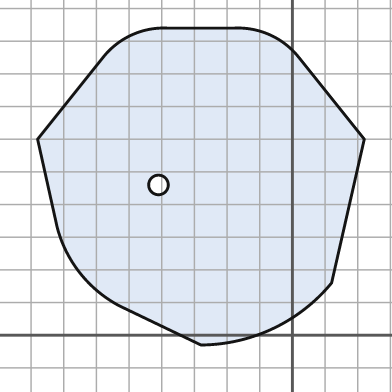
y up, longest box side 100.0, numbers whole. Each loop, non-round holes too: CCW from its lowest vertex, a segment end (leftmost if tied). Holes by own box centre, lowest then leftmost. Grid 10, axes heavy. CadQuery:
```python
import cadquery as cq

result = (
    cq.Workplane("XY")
    .moveTo(-28.0, -3.0)
    .threePointArc((-6.0, 2.0), (12.0, 16.0))
    .lineTo(22.0, 60.0)
    .lineTo(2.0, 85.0)
    .threePointArc((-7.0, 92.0), (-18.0, 94.0))
    .lineTo(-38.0, 94.0)
    .threePointArc((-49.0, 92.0), (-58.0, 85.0))
    .lineTo(-78.0, 60.0)
    .lineTo(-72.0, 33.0)
    .threePointArc((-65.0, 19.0), (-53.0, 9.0))
    .close()
    .moveTo(-41.0, 46.0)
    .circle(3.0)
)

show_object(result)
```